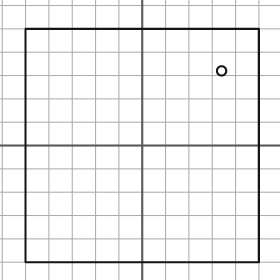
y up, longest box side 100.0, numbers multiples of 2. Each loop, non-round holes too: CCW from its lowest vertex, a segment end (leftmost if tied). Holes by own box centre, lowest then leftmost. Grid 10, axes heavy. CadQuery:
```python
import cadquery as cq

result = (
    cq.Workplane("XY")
    .moveTo(-50.0, -50.0)
    .lineTo(50.0, -50.0)
    .lineTo(50.0, 50.0)
    .lineTo(-50.0, 50.0)
    .close()
    .moveTo(34.0, 32.0)
    .circle(2.0)
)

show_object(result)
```